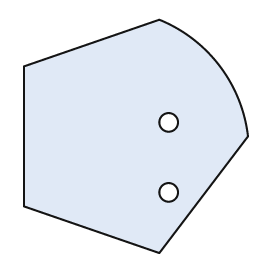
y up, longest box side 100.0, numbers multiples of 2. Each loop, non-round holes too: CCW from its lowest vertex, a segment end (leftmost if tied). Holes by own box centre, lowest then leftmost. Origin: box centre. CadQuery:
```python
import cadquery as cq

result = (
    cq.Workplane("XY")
    .moveTo(10.0, -50.0)
    .lineTo(48.0, 0.0)
    .threePointArc((36.0, 30.0), (10.0, 50.0))
    .lineTo(-48.0, 30.0)
    .lineTo(-48.0, -30.0)
    .close()
    .moveTo(14.0, -24.0)
    .circle(4.0)
    .moveTo(14.0, 6.0)
    .circle(4.0)
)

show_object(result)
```